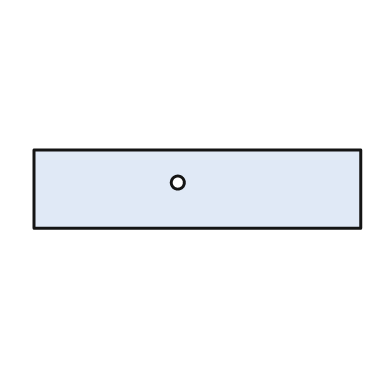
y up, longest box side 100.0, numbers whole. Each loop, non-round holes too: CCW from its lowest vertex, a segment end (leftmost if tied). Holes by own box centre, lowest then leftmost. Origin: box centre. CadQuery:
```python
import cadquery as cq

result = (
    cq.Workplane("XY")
    .moveTo(-50.0, -12.0)
    .lineTo(50.0, -12.0)
    .lineTo(50.0, 12.0)
    .lineTo(-50.0, 12.0)
    .close()
    .moveTo(-6.0, 2.0)
    .circle(2.0)
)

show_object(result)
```